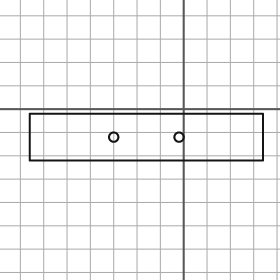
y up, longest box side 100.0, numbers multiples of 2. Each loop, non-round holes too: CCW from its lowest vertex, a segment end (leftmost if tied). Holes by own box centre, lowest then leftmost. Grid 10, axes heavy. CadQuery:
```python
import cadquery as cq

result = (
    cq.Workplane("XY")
    .moveTo(-66.0, -22.0)
    .lineTo(34.0, -22.0)
    .lineTo(34.0, -2.0)
    .lineTo(-66.0, -2.0)
    .close()
    .moveTo(-30.0, -12.0)
    .circle(2.0)
    .moveTo(-2.0, -12.0)
    .circle(2.0)
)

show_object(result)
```